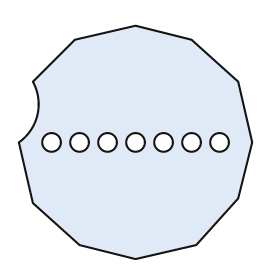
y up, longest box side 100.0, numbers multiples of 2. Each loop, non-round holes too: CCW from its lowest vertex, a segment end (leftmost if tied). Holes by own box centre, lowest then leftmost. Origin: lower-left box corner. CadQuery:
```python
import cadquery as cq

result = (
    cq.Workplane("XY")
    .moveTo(50.0, 0.0)
    .lineTo(76.0, 6.0)
    .lineTo(94.0, 26.0)
    .lineTo(100.0, 50.0)
    .lineTo(94.0, 76.0)
    .lineTo(74.0, 94.0)
    .lineTo(50.0, 100.0)
    .lineTo(24.0, 94.0)
    .lineTo(6.0, 76.0)
    .threePointArc((8.0, 62.0), (0.0, 50.0))
    .lineTo(6.0, 24.0)
    .lineTo(26.0, 6.0)
    .close()
    .moveTo(14.0, 50.0)
    .circle(4.0)
    .moveTo(26.0, 50.0)
    .circle(4.0)
    .moveTo(38.0, 50.0)
    .circle(4.0)
    .moveTo(50.0, 50.0)
    .circle(4.0)
    .moveTo(62.0, 50.0)
    .circle(4.0)
    .moveTo(74.0, 50.0)
    .circle(4.0)
    .moveTo(86.0, 50.0)
    .circle(4.0)
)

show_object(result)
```